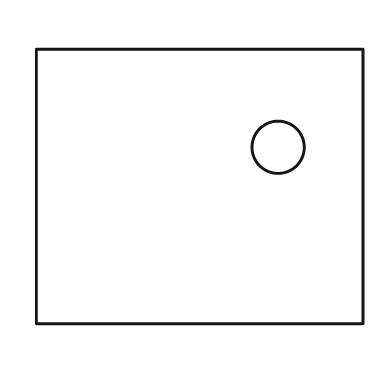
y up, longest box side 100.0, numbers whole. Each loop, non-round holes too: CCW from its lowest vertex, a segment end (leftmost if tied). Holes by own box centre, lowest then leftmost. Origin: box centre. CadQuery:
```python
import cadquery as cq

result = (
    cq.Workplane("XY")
    .moveTo(-50.0, -42.0)
    .lineTo(50.0, -42.0)
    .lineTo(50.0, 42.0)
    .lineTo(-50.0, 42.0)
    .close()
    .moveTo(24.0, 12.0)
    .circle(8.0)
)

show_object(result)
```